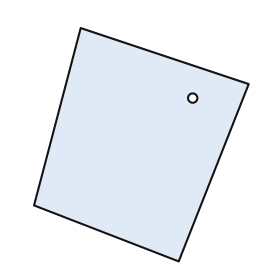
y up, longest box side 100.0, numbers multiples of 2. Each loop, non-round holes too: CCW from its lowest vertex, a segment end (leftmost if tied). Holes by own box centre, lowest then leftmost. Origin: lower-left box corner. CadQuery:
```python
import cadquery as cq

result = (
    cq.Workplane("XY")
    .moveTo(62.0, 0.0)
    .lineTo(92.0, 76.0)
    .lineTo(20.0, 100.0)
    .lineTo(0.0, 24.0)
    .close()
    .moveTo(68.0, 70.0)
    .circle(2.0)
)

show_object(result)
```